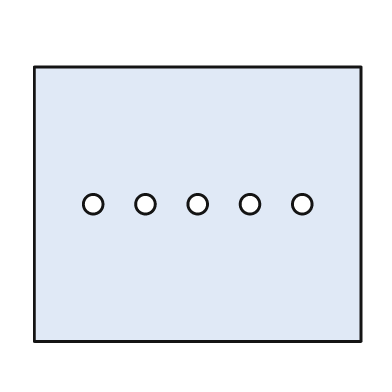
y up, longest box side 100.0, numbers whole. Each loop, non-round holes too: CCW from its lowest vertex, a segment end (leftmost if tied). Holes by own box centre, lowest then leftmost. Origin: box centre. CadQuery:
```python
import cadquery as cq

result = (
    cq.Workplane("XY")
    .moveTo(-50.0, -42.0)
    .lineTo(50.0, -42.0)
    .lineTo(50.0, 42.0)
    .lineTo(-50.0, 42.0)
    .close()
    .moveTo(-32.0, 0.0)
    .circle(3.0)
    .moveTo(-16.0, 0.0)
    .circle(3.0)
    .moveTo(0.0, 0.0)
    .circle(3.0)
    .moveTo(16.0, 0.0)
    .circle(3.0)
    .moveTo(32.0, 0.0)
    .circle(3.0)
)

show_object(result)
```